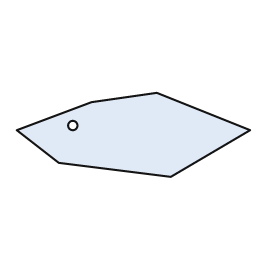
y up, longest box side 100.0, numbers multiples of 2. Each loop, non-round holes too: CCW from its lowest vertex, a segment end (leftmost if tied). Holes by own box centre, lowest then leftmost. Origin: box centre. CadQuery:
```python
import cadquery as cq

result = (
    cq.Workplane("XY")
    .moveTo(16.0, -18.0)
    .lineTo(50.0, 2.0)
    .lineTo(10.0, 18.0)
    .lineTo(-18.0, 14.0)
    .lineTo(-50.0, 2.0)
    .lineTo(-32.0, -12.0)
    .close()
    .moveTo(-26.0, 4.0)
    .circle(2.0)
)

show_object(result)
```